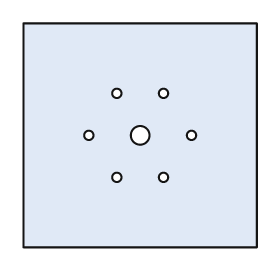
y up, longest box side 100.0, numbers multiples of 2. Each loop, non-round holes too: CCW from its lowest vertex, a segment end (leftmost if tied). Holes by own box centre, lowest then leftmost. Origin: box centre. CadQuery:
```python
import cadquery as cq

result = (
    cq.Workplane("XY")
    .moveTo(-50.0, -48.0)
    .lineTo(50.0, -48.0)
    .lineTo(50.0, 48.0)
    .lineTo(-50.0, 48.0)
    .close()
    .moveTo(-10.0, -18.0)
    .circle(2.0)
    .moveTo(10.0, -18.0)
    .circle(2.0)
    .moveTo(-22.0, 0.0)
    .circle(2.0)
    .moveTo(0.0, 0.0)
    .circle(4.0)
    .moveTo(22.0, 0.0)
    .circle(2.0)
    .moveTo(-10.0, 18.0)
    .circle(2.0)
    .moveTo(10.0, 18.0)
    .circle(2.0)
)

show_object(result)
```